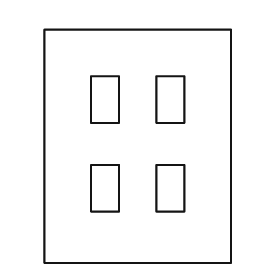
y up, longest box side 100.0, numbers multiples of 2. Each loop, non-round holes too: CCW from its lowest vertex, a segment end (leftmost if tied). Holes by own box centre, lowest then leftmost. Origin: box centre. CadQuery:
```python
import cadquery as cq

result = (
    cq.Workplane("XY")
    .moveTo(-40.0, -50.0)
    .lineTo(40.0, -50.0)
    .lineTo(40.0, 50.0)
    .lineTo(-40.0, 50.0)
    .close()
    .moveTo(-20.0, -28.0)
    .lineTo(-8.0, -28.0)
    .lineTo(-8.0, -8.0)
    .lineTo(-20.0, -8.0)
    .close()
    .moveTo(8.0, -28.0)
    .lineTo(20.0, -28.0)
    .lineTo(20.0, -8.0)
    .lineTo(8.0, -8.0)
    .close()
    .moveTo(-20.0, 10.0)
    .lineTo(-8.0, 10.0)
    .lineTo(-8.0, 30.0)
    .lineTo(-20.0, 30.0)
    .close()
    .moveTo(8.0, 10.0)
    .lineTo(20.0, 10.0)
    .lineTo(20.0, 30.0)
    .lineTo(8.0, 30.0)
    .close()
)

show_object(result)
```